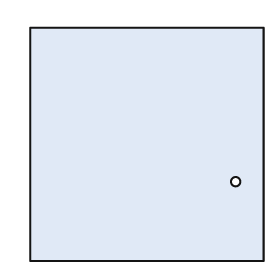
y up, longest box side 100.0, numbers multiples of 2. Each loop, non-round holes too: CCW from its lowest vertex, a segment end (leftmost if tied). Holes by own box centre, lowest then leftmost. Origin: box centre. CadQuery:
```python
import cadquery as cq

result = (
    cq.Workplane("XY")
    .moveTo(-50.0, -50.0)
    .lineTo(50.0, -50.0)
    .lineTo(50.0, 50.0)
    .lineTo(-50.0, 50.0)
    .close()
    .moveTo(38.0, -16.0)
    .circle(2.0)
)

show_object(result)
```